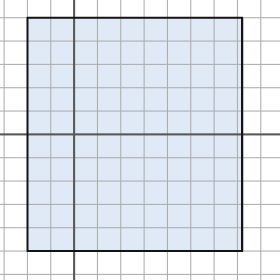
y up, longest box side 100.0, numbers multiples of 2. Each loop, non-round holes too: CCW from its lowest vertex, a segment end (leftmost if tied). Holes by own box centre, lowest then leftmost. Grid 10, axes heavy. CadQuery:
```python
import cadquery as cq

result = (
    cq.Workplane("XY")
    .moveTo(-20.0, -50.0)
    .lineTo(72.0, -50.0)
    .lineTo(72.0, 50.0)
    .lineTo(-20.0, 50.0)
    .close()
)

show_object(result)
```